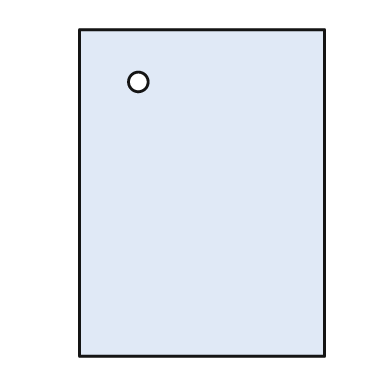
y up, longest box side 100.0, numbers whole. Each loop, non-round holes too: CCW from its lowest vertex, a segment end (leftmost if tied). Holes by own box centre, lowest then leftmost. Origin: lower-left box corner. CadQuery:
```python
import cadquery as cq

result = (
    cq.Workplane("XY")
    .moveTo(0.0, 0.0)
    .lineTo(75.0, 0.0)
    .lineTo(75.0, 100.0)
    .lineTo(0.0, 100.0)
    .close()
    .moveTo(18.0, 84.0)
    .circle(3.0)
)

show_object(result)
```